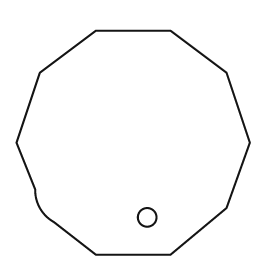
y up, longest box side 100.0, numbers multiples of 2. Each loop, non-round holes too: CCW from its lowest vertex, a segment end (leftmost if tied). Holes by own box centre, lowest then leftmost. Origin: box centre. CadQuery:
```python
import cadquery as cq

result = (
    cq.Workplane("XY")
    .moveTo(-16.0, -48.0)
    .lineTo(16.0, -48.0)
    .lineTo(40.0, -28.0)
    .lineTo(50.0, 0.0)
    .lineTo(40.0, 30.0)
    .lineTo(16.0, 48.0)
    .lineTo(-16.0, 48.0)
    .lineTo(-40.0, 30.0)
    .lineTo(-50.0, 0.0)
    .lineTo(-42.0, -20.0)
    .threePointArc((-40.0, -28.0), (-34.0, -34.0))
    .close()
    .moveTo(6.0, -32.0)
    .circle(4.0)
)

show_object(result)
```